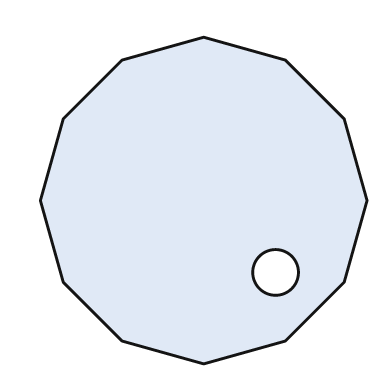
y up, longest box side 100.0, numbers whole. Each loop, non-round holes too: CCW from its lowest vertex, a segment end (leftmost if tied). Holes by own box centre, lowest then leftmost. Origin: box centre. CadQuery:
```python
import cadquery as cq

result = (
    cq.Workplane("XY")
    .moveTo(0.0, -50.0)
    .lineTo(25.0, -43.0)
    .lineTo(43.0, -25.0)
    .lineTo(50.0, 0.0)
    .lineTo(43.0, 25.0)
    .lineTo(25.0, 43.0)
    .lineTo(0.0, 50.0)
    .lineTo(-25.0, 43.0)
    .lineTo(-43.0, 25.0)
    .lineTo(-50.0, 0.0)
    .lineTo(-43.0, -25.0)
    .lineTo(-25.0, -43.0)
    .close()
    .moveTo(22.0, -22.0)
    .circle(7.0)
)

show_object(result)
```